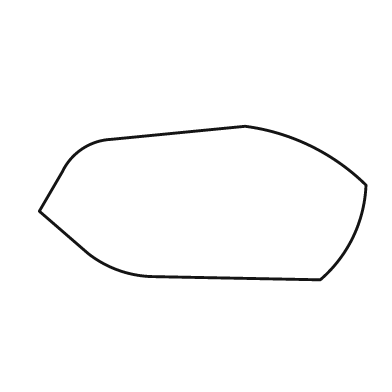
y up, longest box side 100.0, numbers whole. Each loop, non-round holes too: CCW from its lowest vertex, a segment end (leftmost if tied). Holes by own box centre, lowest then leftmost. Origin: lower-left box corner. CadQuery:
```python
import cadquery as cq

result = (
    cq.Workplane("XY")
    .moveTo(86.0, 0.0)
    .threePointArc((96.0, 13.0), (100.0, 29.0))
    .threePointArc((83.0, 41.0), (63.0, 47.0))
    .lineTo(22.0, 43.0)
    .threePointArc((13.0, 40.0), (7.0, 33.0))
    .lineTo(0.0, 21.0)
    .lineTo(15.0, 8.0)
    .threePointArc((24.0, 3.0), (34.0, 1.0))
    .close()
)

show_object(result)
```